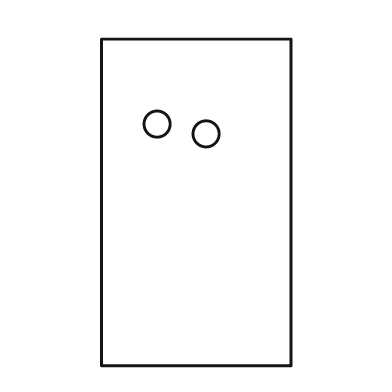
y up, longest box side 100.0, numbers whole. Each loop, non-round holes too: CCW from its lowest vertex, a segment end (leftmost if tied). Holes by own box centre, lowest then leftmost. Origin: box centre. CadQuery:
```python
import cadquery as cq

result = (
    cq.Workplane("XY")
    .moveTo(-29.0, -50.0)
    .lineTo(29.0, -50.0)
    .lineTo(29.0, 50.0)
    .lineTo(-29.0, 50.0)
    .close()
    .moveTo(3.0, 21.0)
    .circle(4.0)
    .moveTo(-12.0, 24.0)
    .circle(4.0)
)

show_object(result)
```